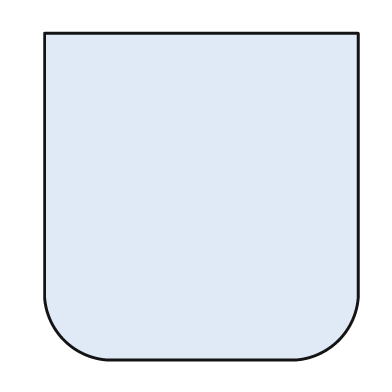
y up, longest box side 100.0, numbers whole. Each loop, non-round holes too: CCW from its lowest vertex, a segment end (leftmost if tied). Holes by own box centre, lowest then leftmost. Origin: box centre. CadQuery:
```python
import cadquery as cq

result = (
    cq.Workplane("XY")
    .moveTo(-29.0, -50.0)
    .lineTo(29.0, -50.0)
    .threePointArc((42.0, -44.0), (48.0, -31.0))
    .lineTo(48.0, 50.0)
    .lineTo(-48.0, 50.0)
    .lineTo(-48.0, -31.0)
    .threePointArc((-42.0, -44.0), (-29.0, -50.0))
    .close()
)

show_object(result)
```